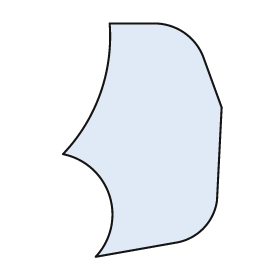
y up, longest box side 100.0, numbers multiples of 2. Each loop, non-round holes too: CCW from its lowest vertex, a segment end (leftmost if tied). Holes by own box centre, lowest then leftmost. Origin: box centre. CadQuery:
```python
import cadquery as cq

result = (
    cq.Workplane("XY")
    .moveTo(-20.0, -50.0)
    .lineTo(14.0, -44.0)
    .threePointArc((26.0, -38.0), (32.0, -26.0))
    .lineTo(34.0, 14.0)
    .lineTo(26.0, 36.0)
    .threePointArc((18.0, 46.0), (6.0, 50.0))
    .lineTo(-14.0, 50.0)
    .threePointArc((-18.0, 20.0), (-34.0, -6.0))
    .threePointArc((-14.0, -24.0), (-20.0, -50.0))
    .close()
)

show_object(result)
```